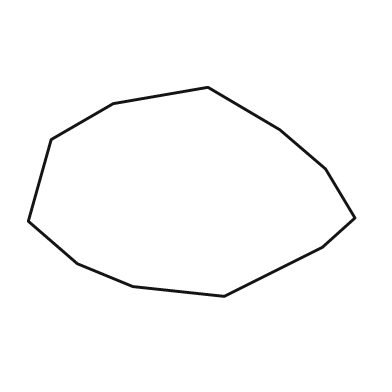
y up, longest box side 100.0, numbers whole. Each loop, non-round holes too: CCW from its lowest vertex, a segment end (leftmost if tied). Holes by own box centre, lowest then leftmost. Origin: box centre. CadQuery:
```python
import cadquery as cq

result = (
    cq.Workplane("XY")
    .moveTo(10.0, -32.0)
    .lineTo(40.0, -17.0)
    .lineTo(50.0, -8.0)
    .lineTo(41.0, 7.0)
    .lineTo(27.0, 19.0)
    .lineTo(5.0, 32.0)
    .lineTo(-24.0, 27.0)
    .lineTo(-43.0, 16.0)
    .lineTo(-50.0, -9.0)
    .lineTo(-35.0, -22.0)
    .lineTo(-18.0, -29.0)
    .close()
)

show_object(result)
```